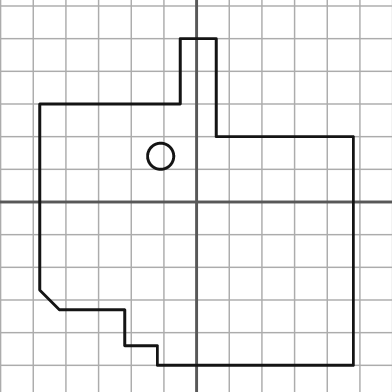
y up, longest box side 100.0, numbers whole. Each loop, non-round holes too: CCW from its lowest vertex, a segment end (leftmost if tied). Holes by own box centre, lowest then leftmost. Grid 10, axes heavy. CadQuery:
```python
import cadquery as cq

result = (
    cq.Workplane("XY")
    .moveTo(-12.0, -50.0)
    .lineTo(48.0, -50.0)
    .lineTo(48.0, 20.0)
    .lineTo(6.0, 20.0)
    .lineTo(6.0, 50.0)
    .lineTo(-5.0, 50.0)
    .lineTo(-5.0, 30.0)
    .lineTo(-48.0, 30.0)
    .lineTo(-48.0, -27.0)
    .lineTo(-42.0, -33.0)
    .lineTo(-22.0, -33.0)
    .lineTo(-22.0, -44.0)
    .lineTo(-12.0, -44.0)
    .close()
    .moveTo(-11.0, 14.0)
    .circle(4.0)
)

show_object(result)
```